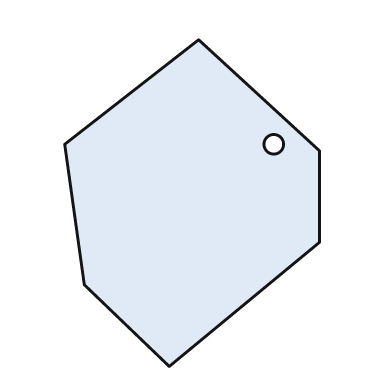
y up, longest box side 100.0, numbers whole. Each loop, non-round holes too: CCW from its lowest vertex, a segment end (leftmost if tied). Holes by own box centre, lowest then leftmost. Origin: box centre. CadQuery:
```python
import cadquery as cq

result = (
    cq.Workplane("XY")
    .moveTo(-7.0, -50.0)
    .lineTo(39.0, -12.0)
    .lineTo(39.0, 16.0)
    .lineTo(2.0, 50.0)
    .lineTo(-39.0, 18.0)
    .lineTo(-33.0, -25.0)
    .close()
    .moveTo(25.0, 18.0)
    .circle(3.0)
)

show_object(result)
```